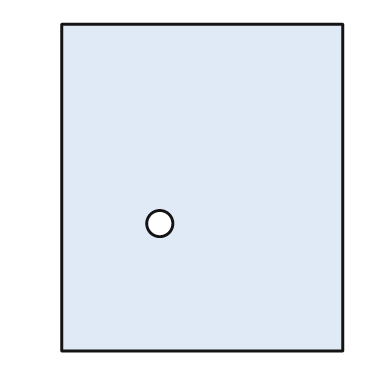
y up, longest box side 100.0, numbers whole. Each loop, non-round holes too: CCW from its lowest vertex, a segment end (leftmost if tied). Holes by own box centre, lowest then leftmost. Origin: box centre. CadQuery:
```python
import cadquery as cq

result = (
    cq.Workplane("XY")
    .moveTo(-43.0, -50.0)
    .lineTo(43.0, -50.0)
    .lineTo(43.0, 50.0)
    .lineTo(-43.0, 50.0)
    .close()
    .moveTo(-13.0, -11.0)
    .circle(4.0)
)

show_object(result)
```